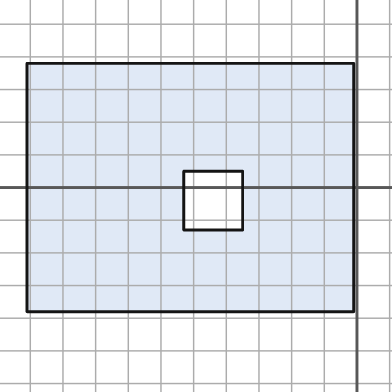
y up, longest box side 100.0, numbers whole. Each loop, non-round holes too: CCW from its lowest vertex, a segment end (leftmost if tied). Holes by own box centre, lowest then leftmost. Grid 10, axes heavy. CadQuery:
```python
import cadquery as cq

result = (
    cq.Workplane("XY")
    .moveTo(-101.0, -38.0)
    .lineTo(-1.0, -38.0)
    .lineTo(-1.0, 38.0)
    .lineTo(-101.0, 38.0)
    .close()
    .moveTo(-53.0, -13.0)
    .lineTo(-35.0, -13.0)
    .lineTo(-35.0, 5.0)
    .lineTo(-53.0, 5.0)
    .close()
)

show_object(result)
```